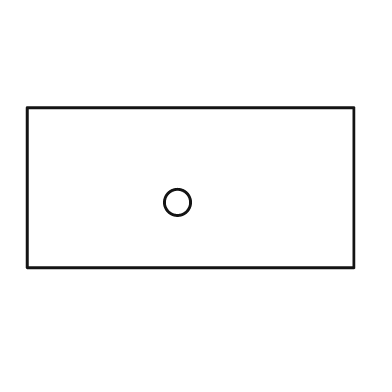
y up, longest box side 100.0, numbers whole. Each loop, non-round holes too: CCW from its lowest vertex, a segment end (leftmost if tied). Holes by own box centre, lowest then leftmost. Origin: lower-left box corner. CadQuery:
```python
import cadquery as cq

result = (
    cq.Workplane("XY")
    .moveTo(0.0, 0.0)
    .lineTo(100.0, 0.0)
    .lineTo(100.0, 49.0)
    .lineTo(0.0, 49.0)
    .close()
    .moveTo(46.0, 20.0)
    .circle(4.0)
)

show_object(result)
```